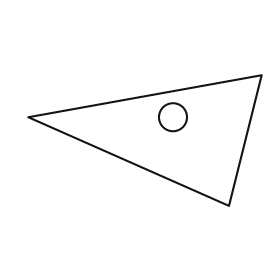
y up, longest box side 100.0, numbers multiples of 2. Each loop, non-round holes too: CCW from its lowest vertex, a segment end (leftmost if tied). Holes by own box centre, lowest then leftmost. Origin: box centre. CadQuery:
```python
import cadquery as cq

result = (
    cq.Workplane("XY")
    .moveTo(36.0, -28.0)
    .lineTo(50.0, 28.0)
    .lineTo(-50.0, 10.0)
    .close()
    .moveTo(12.0, 10.0)
    .circle(6.0)
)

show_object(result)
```